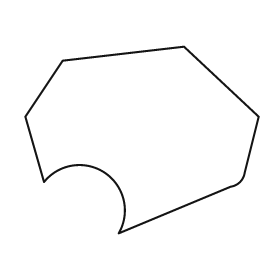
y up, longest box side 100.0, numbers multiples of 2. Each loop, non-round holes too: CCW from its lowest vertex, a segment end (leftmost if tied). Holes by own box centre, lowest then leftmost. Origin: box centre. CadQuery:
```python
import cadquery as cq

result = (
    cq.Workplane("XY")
    .moveTo(-10.0, -40.0)
    .lineTo(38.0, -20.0)
    .threePointArc((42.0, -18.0), (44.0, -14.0))
    .lineTo(50.0, 10.0)
    .lineTo(18.0, 40.0)
    .lineTo(-34.0, 34.0)
    .lineTo(-50.0, 10.0)
    .lineTo(-42.0, -18.0)
    .threePointArc((-16.0, -14.0), (-10.0, -40.0))
    .close()
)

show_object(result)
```